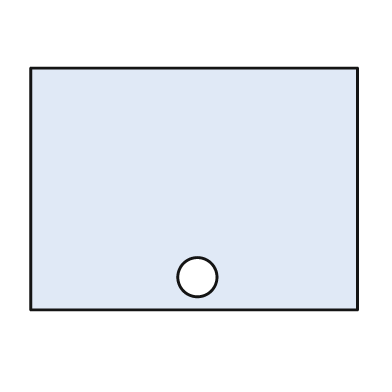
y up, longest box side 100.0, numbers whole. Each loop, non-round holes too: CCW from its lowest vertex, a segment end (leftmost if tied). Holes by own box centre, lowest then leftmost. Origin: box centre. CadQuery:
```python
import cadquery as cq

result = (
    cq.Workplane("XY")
    .moveTo(-50.0, -37.0)
    .lineTo(50.0, -37.0)
    .lineTo(50.0, 37.0)
    .lineTo(-50.0, 37.0)
    .close()
    .moveTo(1.0, -27.0)
    .circle(6.0)
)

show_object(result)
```